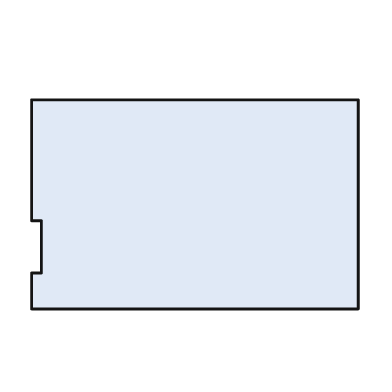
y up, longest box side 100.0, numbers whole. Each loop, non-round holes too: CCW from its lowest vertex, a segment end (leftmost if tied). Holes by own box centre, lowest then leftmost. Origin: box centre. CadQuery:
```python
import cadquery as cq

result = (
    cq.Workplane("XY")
    .moveTo(-50.0, -32.0)
    .lineTo(50.0, -32.0)
    .lineTo(50.0, 32.0)
    .lineTo(-50.0, 32.0)
    .lineTo(-50.0, -5.0)
    .lineTo(-47.0, -5.0)
    .lineTo(-47.0, -21.0)
    .lineTo(-50.0, -21.0)
    .close()
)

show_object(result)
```